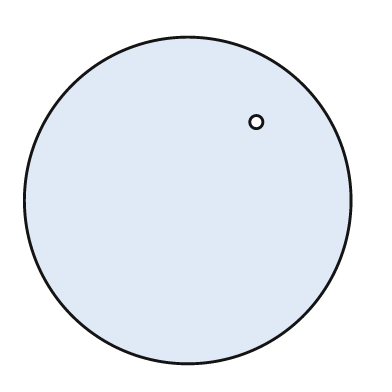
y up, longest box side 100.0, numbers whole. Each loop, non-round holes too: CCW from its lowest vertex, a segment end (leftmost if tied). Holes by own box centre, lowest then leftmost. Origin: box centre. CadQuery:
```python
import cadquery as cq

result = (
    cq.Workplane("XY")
    .moveTo(0.0, 0.0)
    .circle(50.0)
    .moveTo(21.0, 24.0)
    .circle(2.0)
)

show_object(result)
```